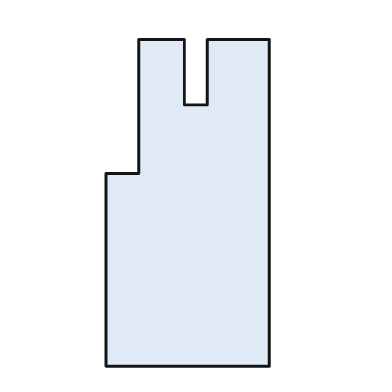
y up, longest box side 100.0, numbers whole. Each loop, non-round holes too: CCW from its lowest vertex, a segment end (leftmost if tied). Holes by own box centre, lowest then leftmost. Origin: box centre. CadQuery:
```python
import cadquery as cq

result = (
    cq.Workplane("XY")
    .moveTo(-25.0, -50.0)
    .lineTo(25.0, -50.0)
    .lineTo(25.0, 50.0)
    .lineTo(6.0, 50.0)
    .lineTo(6.0, 30.0)
    .lineTo(-1.0, 30.0)
    .lineTo(-1.0, 50.0)
    .lineTo(-15.0, 50.0)
    .lineTo(-15.0, 9.0)
    .lineTo(-25.0, 9.0)
    .close()
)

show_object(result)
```